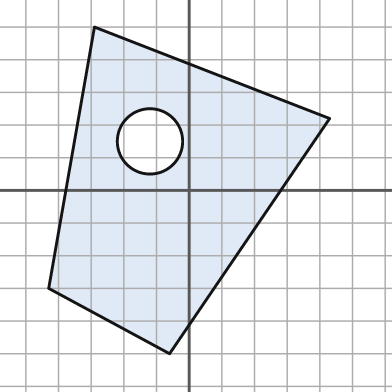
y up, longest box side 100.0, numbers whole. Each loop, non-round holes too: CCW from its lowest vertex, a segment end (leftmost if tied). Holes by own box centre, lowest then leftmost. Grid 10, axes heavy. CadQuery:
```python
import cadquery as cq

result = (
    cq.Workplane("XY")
    .moveTo(-6.0, -50.0)
    .lineTo(43.0, 22.0)
    .lineTo(-29.0, 50.0)
    .lineTo(-43.0, -30.0)
    .close()
    .moveTo(-12.0, 15.0)
    .circle(10.0)
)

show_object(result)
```